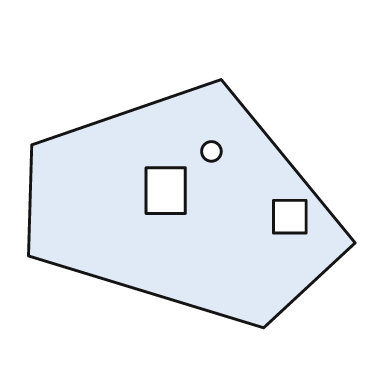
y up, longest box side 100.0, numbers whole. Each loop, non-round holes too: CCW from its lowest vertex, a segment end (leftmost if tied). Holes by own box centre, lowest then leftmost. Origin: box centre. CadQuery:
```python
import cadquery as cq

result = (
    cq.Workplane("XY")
    .moveTo(22.0, -38.0)
    .lineTo(50.0, -12.0)
    .lineTo(9.0, 38.0)
    .lineTo(-49.0, 18.0)
    .lineTo(-50.0, -16.0)
    .close()
    .moveTo(25.0, -9.0)
    .lineTo(35.0, -9.0)
    .lineTo(35.0, 1.0)
    .lineTo(25.0, 1.0)
    .close()
    .moveTo(-14.0, -3.0)
    .lineTo(-2.0, -3.0)
    .lineTo(-2.0, 11.0)
    .lineTo(-14.0, 11.0)
    .close()
    .moveTo(6.0, 16.0)
    .circle(3.0)
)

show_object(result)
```